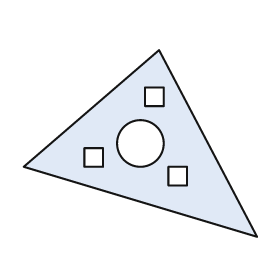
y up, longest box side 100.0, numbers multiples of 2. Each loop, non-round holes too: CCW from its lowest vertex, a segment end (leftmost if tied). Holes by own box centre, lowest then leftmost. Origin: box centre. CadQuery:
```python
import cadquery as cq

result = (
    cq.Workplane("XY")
    .moveTo(50.0, -40.0)
    .lineTo(8.0, 40.0)
    .lineTo(-50.0, -10.0)
    .close()
    .moveTo(12.0, -18.0)
    .lineTo(20.0, -18.0)
    .lineTo(20.0, -10.0)
    .lineTo(12.0, -10.0)
    .close()
    .moveTo(-24.0, -10.0)
    .lineTo(-16.0, -10.0)
    .lineTo(-16.0, -2.0)
    .lineTo(-24.0, -2.0)
    .close()
    .moveTo(0.0, 0.0)
    .circle(10.0)
    .moveTo(2.0, 16.0)
    .lineTo(10.0, 16.0)
    .lineTo(10.0, 24.0)
    .lineTo(2.0, 24.0)
    .close()
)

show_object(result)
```